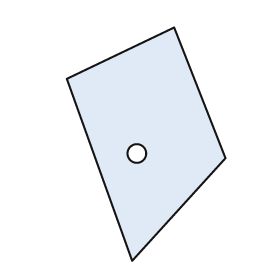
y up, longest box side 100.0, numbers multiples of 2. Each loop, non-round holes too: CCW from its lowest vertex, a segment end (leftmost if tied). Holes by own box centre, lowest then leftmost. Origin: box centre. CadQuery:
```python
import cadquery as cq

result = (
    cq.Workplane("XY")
    .moveTo(-6.0, -50.0)
    .lineTo(34.0, -6.0)
    .lineTo(12.0, 50.0)
    .lineTo(-34.0, 28.0)
    .close()
    .moveTo(-4.0, -4.0)
    .circle(4.0)
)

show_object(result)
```